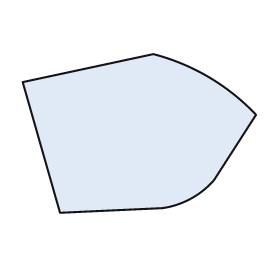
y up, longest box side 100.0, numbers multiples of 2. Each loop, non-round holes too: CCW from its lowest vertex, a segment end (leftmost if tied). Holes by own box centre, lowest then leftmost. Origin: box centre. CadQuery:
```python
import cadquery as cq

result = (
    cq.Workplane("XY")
    .moveTo(-34.0, -34.0)
    .lineTo(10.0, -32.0)
    .threePointArc((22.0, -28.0), (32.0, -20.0))
    .lineTo(50.0, 8.0)
    .threePointArc((30.0, 24.0), (6.0, 34.0))
    .lineTo(-50.0, 22.0)
    .close()
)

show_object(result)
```